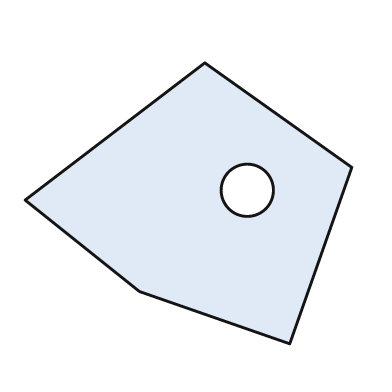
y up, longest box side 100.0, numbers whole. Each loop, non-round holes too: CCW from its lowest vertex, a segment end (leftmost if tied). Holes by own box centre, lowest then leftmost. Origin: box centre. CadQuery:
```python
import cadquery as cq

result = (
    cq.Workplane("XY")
    .moveTo(31.0, -43.0)
    .lineTo(50.0, 11.0)
    .lineTo(5.0, 43.0)
    .lineTo(-50.0, 1.0)
    .lineTo(-15.0, -27.0)
    .close()
    .moveTo(18.0, 4.0)
    .circle(8.0)
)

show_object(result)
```